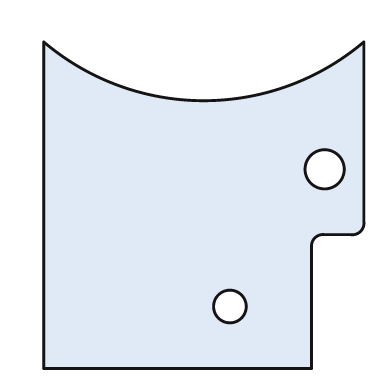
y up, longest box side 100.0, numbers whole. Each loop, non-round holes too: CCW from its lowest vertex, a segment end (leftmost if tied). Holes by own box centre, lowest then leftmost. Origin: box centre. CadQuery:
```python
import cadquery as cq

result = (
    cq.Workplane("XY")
    .moveTo(-49.0, -50.0)
    .lineTo(33.0, -50.0)
    .lineTo(33.0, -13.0)
    .threePointArc((34.0, -10.0), (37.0, -9.0))
    .lineTo(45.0, -9.0)
    .threePointArc((48.0, -8.0), (49.0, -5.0))
    .lineTo(49.0, 50.0)
    .threePointArc((0.0, 32.0), (-49.0, 50.0))
    .close()
    .moveTo(8.0, -31.0)
    .circle(5.0)
    .moveTo(37.0, 11.0)
    .circle(6.0)
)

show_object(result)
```